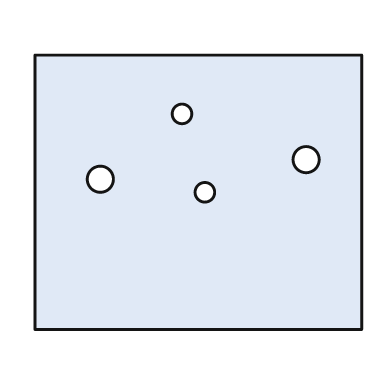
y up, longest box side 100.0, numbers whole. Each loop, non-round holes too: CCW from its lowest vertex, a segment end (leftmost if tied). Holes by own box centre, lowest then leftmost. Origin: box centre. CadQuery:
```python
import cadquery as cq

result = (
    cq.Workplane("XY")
    .moveTo(-50.0, -42.0)
    .lineTo(50.0, -42.0)
    .lineTo(50.0, 42.0)
    .lineTo(-50.0, 42.0)
    .close()
    .moveTo(2.0, 0.0)
    .circle(3.0)
    .moveTo(-30.0, 4.0)
    .circle(4.0)
    .moveTo(33.0, 10.0)
    .circle(4.0)
    .moveTo(-5.0, 24.0)
    .circle(3.0)
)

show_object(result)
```